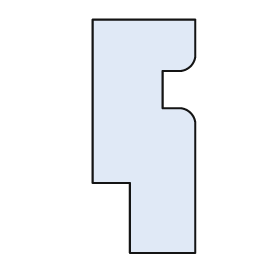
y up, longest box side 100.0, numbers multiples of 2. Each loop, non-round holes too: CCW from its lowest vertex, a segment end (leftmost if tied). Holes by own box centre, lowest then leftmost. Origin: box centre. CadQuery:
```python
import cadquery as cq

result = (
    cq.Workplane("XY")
    .moveTo(-6.0, -50.0)
    .lineTo(22.0, -50.0)
    .lineTo(22.0, 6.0)
    .threePointArc((20.0, 10.0), (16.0, 12.0))
    .lineTo(8.0, 12.0)
    .lineTo(8.0, 28.0)
    .lineTo(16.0, 28.0)
    .threePointArc((20.0, 30.0), (22.0, 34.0))
    .lineTo(22.0, 50.0)
    .lineTo(-22.0, 50.0)
    .lineTo(-22.0, -20.0)
    .lineTo(-6.0, -20.0)
    .close()
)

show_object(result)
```